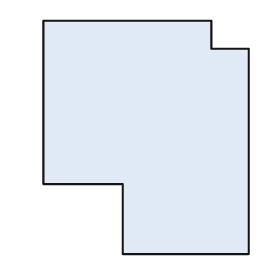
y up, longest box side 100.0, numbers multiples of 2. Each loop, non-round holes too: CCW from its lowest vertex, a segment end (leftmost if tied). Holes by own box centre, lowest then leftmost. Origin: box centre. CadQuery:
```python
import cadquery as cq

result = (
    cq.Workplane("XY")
    .moveTo(-10.0, -50.0)
    .lineTo(44.0, -50.0)
    .lineTo(44.0, 38.0)
    .lineTo(28.0, 38.0)
    .lineTo(28.0, 50.0)
    .lineTo(-44.0, 50.0)
    .lineTo(-44.0, -20.0)
    .lineTo(-10.0, -20.0)
    .close()
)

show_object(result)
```